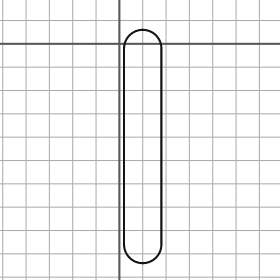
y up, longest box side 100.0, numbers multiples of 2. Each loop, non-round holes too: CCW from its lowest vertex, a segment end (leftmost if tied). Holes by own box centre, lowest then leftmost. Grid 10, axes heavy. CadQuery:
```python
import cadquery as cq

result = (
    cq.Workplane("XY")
    .moveTo(2.0, -86.0)
    .threePointArc((10.0, -94.0), (18.0, -86.0))
    .lineTo(18.0, -2.0)
    .threePointArc((10.0, 6.0), (2.0, -2.0))
    .close()
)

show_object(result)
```